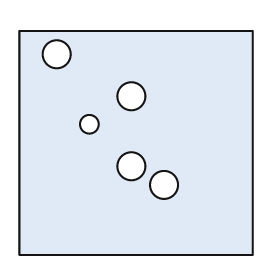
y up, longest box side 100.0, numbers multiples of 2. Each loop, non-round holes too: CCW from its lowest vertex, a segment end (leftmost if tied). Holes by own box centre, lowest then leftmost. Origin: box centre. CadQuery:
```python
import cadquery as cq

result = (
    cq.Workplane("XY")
    .moveTo(-50.0, -48.0)
    .lineTo(50.0, -48.0)
    .lineTo(50.0, 48.0)
    .lineTo(-50.0, 48.0)
    .close()
    .moveTo(12.0, -18.0)
    .circle(6.0)
    .moveTo(-2.0, -10.0)
    .circle(6.0)
    .moveTo(-20.0, 8.0)
    .circle(4.0)
    .moveTo(-2.0, 20.0)
    .circle(6.0)
    .moveTo(-34.0, 38.0)
    .circle(6.0)
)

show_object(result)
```